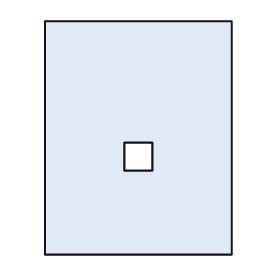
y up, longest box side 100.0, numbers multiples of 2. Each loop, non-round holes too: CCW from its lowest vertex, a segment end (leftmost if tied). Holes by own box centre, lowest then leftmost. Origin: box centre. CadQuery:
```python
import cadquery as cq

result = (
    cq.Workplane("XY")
    .moveTo(-40.0, -50.0)
    .lineTo(40.0, -50.0)
    .lineTo(40.0, 50.0)
    .lineTo(-40.0, 50.0)
    .close()
    .moveTo(-6.0, -14.0)
    .lineTo(6.0, -14.0)
    .lineTo(6.0, -2.0)
    .lineTo(-6.0, -2.0)
    .close()
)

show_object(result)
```